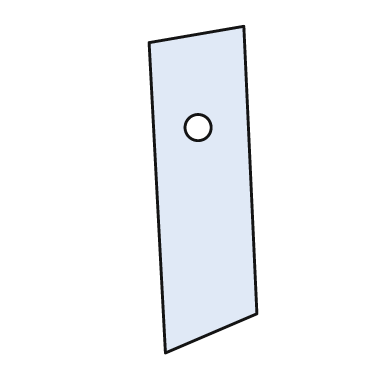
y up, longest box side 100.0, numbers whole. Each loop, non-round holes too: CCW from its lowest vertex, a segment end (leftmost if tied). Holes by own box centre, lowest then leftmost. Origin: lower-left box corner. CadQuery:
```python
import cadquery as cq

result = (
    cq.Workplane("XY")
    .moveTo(5.0, 0.0)
    .lineTo(33.0, 12.0)
    .lineTo(29.0, 100.0)
    .lineTo(0.0, 95.0)
    .close()
    .moveTo(15.0, 69.0)
    .circle(4.0)
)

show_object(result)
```